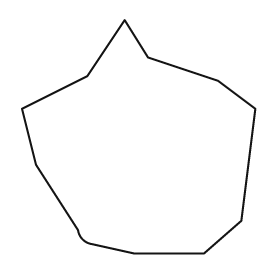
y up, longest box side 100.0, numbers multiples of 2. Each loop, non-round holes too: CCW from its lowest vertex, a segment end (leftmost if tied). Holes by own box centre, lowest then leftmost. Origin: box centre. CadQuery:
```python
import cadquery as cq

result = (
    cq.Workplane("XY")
    .moveTo(-2.0, -50.0)
    .lineTo(28.0, -50.0)
    .lineTo(44.0, -36.0)
    .lineTo(50.0, 12.0)
    .lineTo(34.0, 24.0)
    .lineTo(4.0, 34.0)
    .lineTo(-6.0, 50.0)
    .lineTo(-22.0, 26.0)
    .lineTo(-50.0, 12.0)
    .lineTo(-44.0, -12.0)
    .lineTo(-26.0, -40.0)
    .threePointArc((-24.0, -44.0), (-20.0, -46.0))
    .close()
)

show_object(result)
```